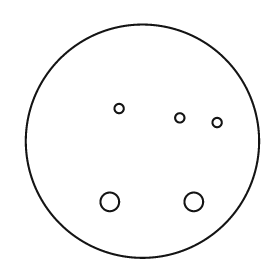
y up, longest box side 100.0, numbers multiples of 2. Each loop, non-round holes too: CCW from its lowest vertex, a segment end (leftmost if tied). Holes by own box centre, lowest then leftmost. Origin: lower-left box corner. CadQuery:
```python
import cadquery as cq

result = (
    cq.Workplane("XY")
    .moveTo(50.0, 50.0)
    .circle(50.0)
    .moveTo(36.0, 24.0)
    .circle(4.0)
    .moveTo(72.0, 24.0)
    .circle(4.0)
    .moveTo(82.0, 58.0)
    .circle(2.0)
    .moveTo(66.0, 60.0)
    .circle(2.0)
    .moveTo(40.0, 64.0)
    .circle(2.0)
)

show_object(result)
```